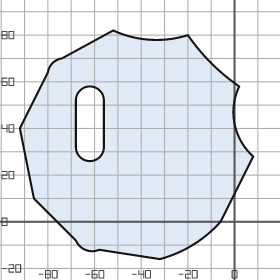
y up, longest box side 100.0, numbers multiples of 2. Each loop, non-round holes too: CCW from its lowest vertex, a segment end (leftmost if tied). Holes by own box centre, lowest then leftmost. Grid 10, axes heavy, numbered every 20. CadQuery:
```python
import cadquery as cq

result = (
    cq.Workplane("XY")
    .moveTo(-32.0, -16.0)
    .threePointArc((-18.0, -10.0), (-6.0, 0.0))
    .lineTo(8.0, 28.0)
    .threePointArc((0.0, 42.0), (2.0, 58.0))
    .threePointArc((-10.0, 68.0), (-20.0, 80.0))
    .threePointArc((-36.0, 78.0), (-52.0, 82.0))
    .lineTo(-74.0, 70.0)
    .threePointArc((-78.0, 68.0), (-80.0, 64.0))
    .lineTo(-92.0, 40.0)
    .lineTo(-86.0, 10.0)
    .lineTo(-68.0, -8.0)
    .threePointArc((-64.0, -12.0), (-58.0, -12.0))
    .close()
    .moveTo(-68.0, 32.0)
    .threePointArc((-62.0, 26.0), (-56.0, 32.0))
    .lineTo(-56.0, 52.0)
    .threePointArc((-62.0, 58.0), (-68.0, 52.0))
    .close()
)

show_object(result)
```